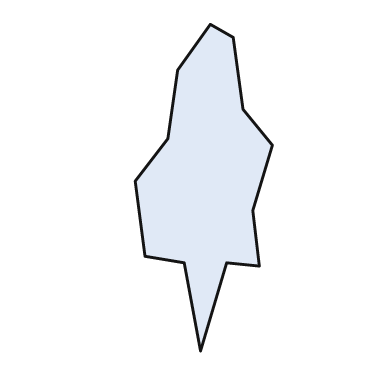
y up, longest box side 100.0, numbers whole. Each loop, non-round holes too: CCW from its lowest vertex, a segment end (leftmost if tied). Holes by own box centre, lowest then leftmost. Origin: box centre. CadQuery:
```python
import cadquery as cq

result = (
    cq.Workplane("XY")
    .moveTo(-1.0, -50.0)
    .lineTo(7.0, -23.0)
    .lineTo(17.0, -24.0)
    .lineTo(15.0, -7.0)
    .lineTo(21.0, 13.0)
    .lineTo(12.0, 24.0)
    .lineTo(9.0, 46.0)
    .lineTo(2.0, 50.0)
    .lineTo(-8.0, 36.0)
    .lineTo(-11.0, 15.0)
    .lineTo(-21.0, 2.0)
    .lineTo(-18.0, -21.0)
    .lineTo(-6.0, -23.0)
    .close()
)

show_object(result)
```